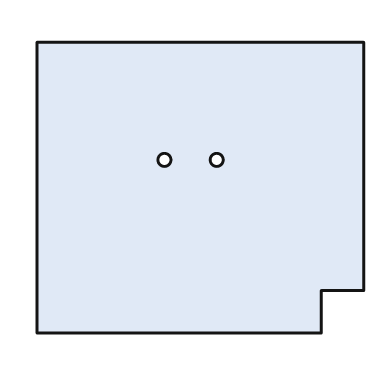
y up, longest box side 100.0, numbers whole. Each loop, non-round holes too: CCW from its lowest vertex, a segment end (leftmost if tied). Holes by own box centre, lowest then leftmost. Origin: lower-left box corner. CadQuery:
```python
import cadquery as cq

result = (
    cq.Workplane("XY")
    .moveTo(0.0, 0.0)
    .lineTo(87.0, 0.0)
    .lineTo(87.0, 13.0)
    .lineTo(100.0, 13.0)
    .lineTo(100.0, 89.0)
    .lineTo(0.0, 89.0)
    .close()
    .moveTo(39.0, 53.0)
    .circle(2.0)
    .moveTo(55.0, 53.0)
    .circle(2.0)
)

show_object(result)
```